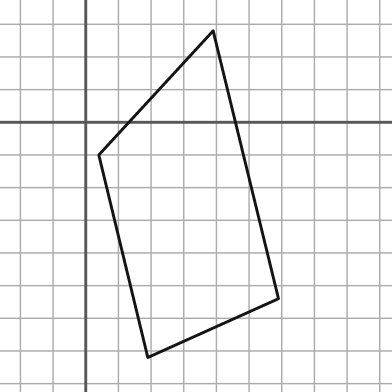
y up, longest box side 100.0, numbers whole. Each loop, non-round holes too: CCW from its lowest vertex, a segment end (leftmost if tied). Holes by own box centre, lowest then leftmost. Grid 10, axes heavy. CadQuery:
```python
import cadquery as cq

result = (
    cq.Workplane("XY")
    .moveTo(19.0, -72.0)
    .lineTo(59.0, -54.0)
    .lineTo(39.0, 28.0)
    .lineTo(4.0, -10.0)
    .close()
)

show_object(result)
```